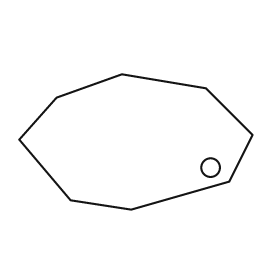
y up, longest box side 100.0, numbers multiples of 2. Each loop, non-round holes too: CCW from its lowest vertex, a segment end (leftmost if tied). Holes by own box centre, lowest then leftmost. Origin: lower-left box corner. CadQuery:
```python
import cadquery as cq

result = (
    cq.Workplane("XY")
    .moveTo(48.0, 0.0)
    .lineTo(90.0, 12.0)
    .lineTo(100.0, 32.0)
    .lineTo(80.0, 52.0)
    .lineTo(44.0, 58.0)
    .lineTo(16.0, 48.0)
    .lineTo(0.0, 30.0)
    .lineTo(22.0, 4.0)
    .close()
    .moveTo(82.0, 18.0)
    .circle(4.0)
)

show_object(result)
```